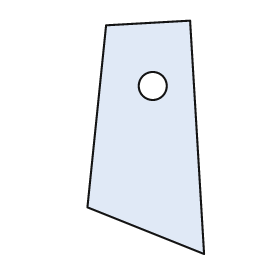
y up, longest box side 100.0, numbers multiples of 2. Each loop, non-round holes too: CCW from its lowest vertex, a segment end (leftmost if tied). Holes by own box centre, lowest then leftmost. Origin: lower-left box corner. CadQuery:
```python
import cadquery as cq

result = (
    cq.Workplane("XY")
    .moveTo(50.0, 0.0)
    .lineTo(44.0, 100.0)
    .lineTo(8.0, 98.0)
    .lineTo(0.0, 20.0)
    .close()
    .moveTo(28.0, 72.0)
    .circle(6.0)
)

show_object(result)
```